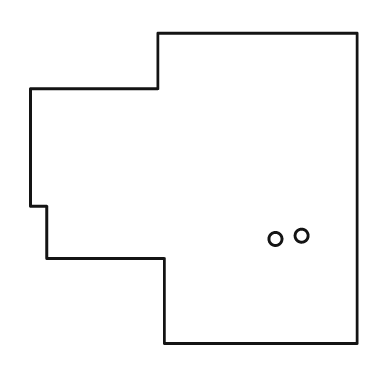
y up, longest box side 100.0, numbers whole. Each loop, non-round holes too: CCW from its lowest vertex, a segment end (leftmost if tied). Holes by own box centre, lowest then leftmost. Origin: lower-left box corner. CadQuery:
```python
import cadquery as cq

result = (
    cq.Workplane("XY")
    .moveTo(41.0, 0.0)
    .lineTo(100.0, 0.0)
    .lineTo(100.0, 95.0)
    .lineTo(39.0, 95.0)
    .lineTo(39.0, 78.0)
    .lineTo(0.0, 78.0)
    .lineTo(0.0, 42.0)
    .lineTo(5.0, 42.0)
    .lineTo(5.0, 26.0)
    .lineTo(41.0, 26.0)
    .close()
    .moveTo(75.0, 32.0)
    .circle(2.0)
    .moveTo(83.0, 33.0)
    .circle(2.0)
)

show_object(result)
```